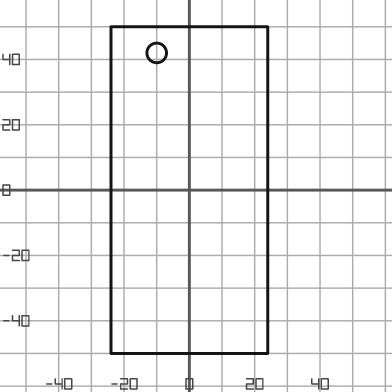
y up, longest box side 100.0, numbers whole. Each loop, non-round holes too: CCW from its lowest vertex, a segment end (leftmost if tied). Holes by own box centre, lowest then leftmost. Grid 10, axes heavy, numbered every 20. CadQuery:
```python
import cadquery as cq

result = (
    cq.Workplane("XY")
    .moveTo(-24.0, -50.0)
    .lineTo(24.0, -50.0)
    .lineTo(24.0, 50.0)
    .lineTo(-24.0, 50.0)
    .close()
    .moveTo(-10.0, 42.0)
    .circle(3.0)
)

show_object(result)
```